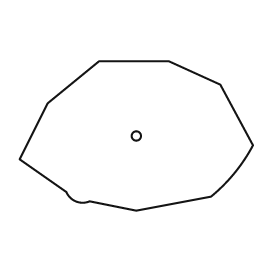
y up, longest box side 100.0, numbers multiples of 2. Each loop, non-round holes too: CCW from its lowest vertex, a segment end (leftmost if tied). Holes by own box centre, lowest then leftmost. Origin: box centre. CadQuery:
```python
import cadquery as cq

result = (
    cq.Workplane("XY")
    .moveTo(0.0, -32.0)
    .lineTo(32.0, -26.0)
    .threePointArc((42.0, -16.0), (50.0, -4.0))
    .lineTo(36.0, 22.0)
    .lineTo(14.0, 32.0)
    .lineTo(-16.0, 32.0)
    .lineTo(-38.0, 14.0)
    .lineTo(-50.0, -10.0)
    .lineTo(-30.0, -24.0)
    .threePointArc((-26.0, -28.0), (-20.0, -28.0))
    .close()
    .moveTo(0.0, 0.0)
    .circle(2.0)
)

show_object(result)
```